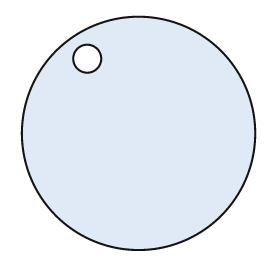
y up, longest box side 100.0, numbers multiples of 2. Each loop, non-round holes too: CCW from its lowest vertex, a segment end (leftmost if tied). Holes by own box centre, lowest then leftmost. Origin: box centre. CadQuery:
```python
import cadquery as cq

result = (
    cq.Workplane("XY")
    .moveTo(0.0, 0.0)
    .circle(50.0)
    .moveTo(-22.0, 32.0)
    .circle(6.0)
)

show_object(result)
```